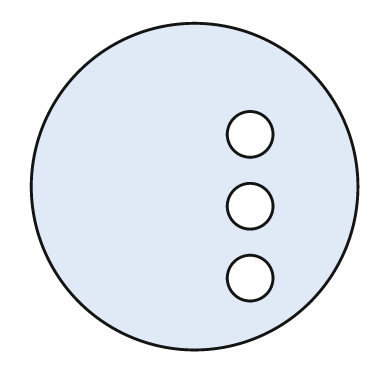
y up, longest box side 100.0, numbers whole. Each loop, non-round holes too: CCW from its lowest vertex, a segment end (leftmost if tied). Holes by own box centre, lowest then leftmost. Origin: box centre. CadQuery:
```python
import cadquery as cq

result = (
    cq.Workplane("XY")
    .moveTo(0.0, 0.0)
    .circle(50.0)
    .moveTo(17.0, -28.0)
    .circle(7.0)
    .moveTo(17.0, -6.0)
    .circle(7.0)
    .moveTo(17.0, 16.0)
    .circle(7.0)
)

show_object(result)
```